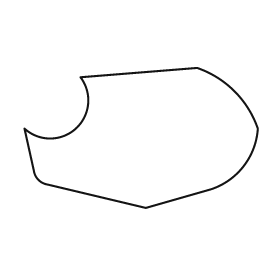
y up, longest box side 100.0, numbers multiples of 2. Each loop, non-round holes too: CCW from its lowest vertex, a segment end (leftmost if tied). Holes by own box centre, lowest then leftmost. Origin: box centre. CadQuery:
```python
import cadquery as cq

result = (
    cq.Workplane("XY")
    .moveTo(2.0, -30.0)
    .lineTo(30.0, -22.0)
    .threePointArc((44.0, -12.0), (50.0, 4.0))
    .threePointArc((40.0, 20.0), (24.0, 30.0))
    .lineTo(-26.0, 26.0)
    .threePointArc((-28.0, 4.0), (-50.0, 4.0))
    .lineTo(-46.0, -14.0)
    .threePointArc((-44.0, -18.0), (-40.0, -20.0))
    .close()
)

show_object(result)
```